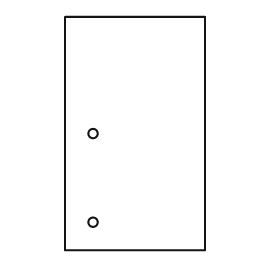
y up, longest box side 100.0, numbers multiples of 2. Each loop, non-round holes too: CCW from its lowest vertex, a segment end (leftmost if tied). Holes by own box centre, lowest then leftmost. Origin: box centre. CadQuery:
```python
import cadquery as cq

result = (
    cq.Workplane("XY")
    .moveTo(-30.0, -50.0)
    .lineTo(30.0, -50.0)
    .lineTo(30.0, 50.0)
    .lineTo(-30.0, 50.0)
    .close()
    .moveTo(-18.0, -38.0)
    .circle(2.0)
    .moveTo(-18.0, 0.0)
    .circle(2.0)
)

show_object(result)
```